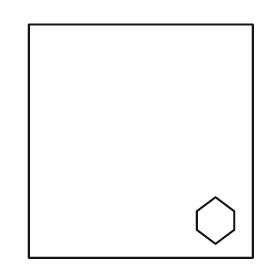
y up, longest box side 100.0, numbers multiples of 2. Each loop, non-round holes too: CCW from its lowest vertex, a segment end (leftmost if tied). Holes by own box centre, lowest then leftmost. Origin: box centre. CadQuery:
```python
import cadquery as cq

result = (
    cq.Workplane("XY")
    .moveTo(-48.0, -50.0)
    .lineTo(48.0, -50.0)
    .lineTo(48.0, 50.0)
    .lineTo(-48.0, 50.0)
    .close()
    .moveTo(32.0, -44.0)
    .lineTo(40.0, -38.0)
    .lineTo(40.0, -30.0)
    .lineTo(32.0, -24.0)
    .lineTo(24.0, -30.0)
    .lineTo(24.0, -38.0)
    .close()
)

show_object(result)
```